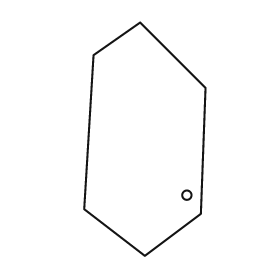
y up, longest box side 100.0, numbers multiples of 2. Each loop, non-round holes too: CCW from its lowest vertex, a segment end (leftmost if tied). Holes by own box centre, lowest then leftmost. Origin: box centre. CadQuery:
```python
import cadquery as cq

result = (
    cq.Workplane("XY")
    .moveTo(0.0, -50.0)
    .lineTo(24.0, -32.0)
    .lineTo(26.0, 22.0)
    .lineTo(-2.0, 50.0)
    .lineTo(-22.0, 36.0)
    .lineTo(-26.0, -30.0)
    .close()
    .moveTo(18.0, -24.0)
    .circle(2.0)
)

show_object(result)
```